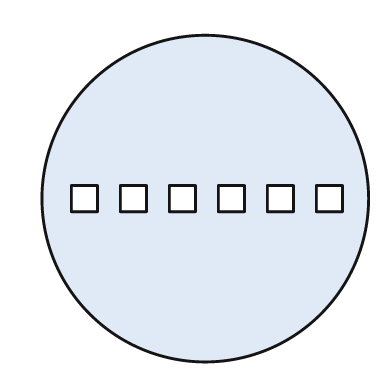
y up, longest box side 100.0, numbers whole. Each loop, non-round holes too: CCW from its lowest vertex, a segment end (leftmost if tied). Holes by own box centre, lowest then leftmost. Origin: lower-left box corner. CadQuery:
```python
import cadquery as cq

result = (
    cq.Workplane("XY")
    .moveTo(50.0, 50.0)
    .circle(50.0)
    .moveTo(9.0, 46.0)
    .lineTo(17.0, 46.0)
    .lineTo(17.0, 54.0)
    .lineTo(9.0, 54.0)
    .close()
    .moveTo(24.0, 46.0)
    .lineTo(32.0, 46.0)
    .lineTo(32.0, 54.0)
    .lineTo(24.0, 54.0)
    .close()
    .moveTo(39.0, 46.0)
    .lineTo(47.0, 46.0)
    .lineTo(47.0, 54.0)
    .lineTo(39.0, 54.0)
    .close()
    .moveTo(54.0, 46.0)
    .lineTo(62.0, 46.0)
    .lineTo(62.0, 54.0)
    .lineTo(54.0, 54.0)
    .close()
    .moveTo(69.0, 46.0)
    .lineTo(77.0, 46.0)
    .lineTo(77.0, 54.0)
    .lineTo(69.0, 54.0)
    .close()
    .moveTo(84.0, 46.0)
    .lineTo(92.0, 46.0)
    .lineTo(92.0, 54.0)
    .lineTo(84.0, 54.0)
    .close()
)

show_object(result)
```